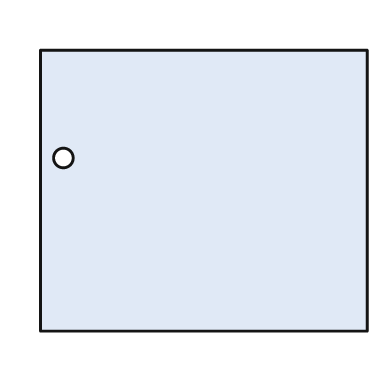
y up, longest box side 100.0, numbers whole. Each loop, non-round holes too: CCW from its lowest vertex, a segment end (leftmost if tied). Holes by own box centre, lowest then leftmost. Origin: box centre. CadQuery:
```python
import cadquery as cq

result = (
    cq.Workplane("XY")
    .moveTo(-50.0, -43.0)
    .lineTo(50.0, -43.0)
    .lineTo(50.0, 43.0)
    .lineTo(-50.0, 43.0)
    .close()
    .moveTo(-43.0, 10.0)
    .circle(3.0)
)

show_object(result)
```